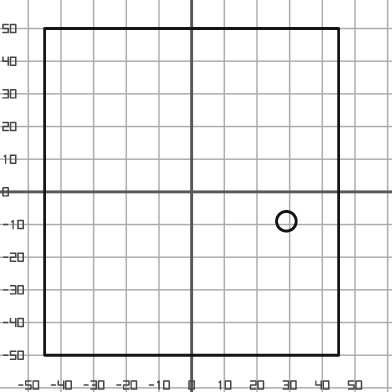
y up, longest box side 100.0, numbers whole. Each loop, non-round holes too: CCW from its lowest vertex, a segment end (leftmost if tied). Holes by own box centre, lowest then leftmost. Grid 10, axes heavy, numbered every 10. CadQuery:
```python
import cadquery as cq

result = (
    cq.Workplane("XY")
    .moveTo(-45.0, -50.0)
    .lineTo(45.0, -50.0)
    .lineTo(45.0, 50.0)
    .lineTo(-45.0, 50.0)
    .close()
    .moveTo(29.0, -9.0)
    .circle(3.0)
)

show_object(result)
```